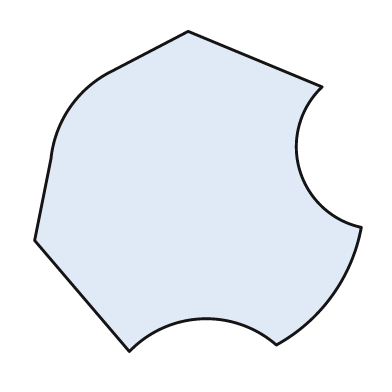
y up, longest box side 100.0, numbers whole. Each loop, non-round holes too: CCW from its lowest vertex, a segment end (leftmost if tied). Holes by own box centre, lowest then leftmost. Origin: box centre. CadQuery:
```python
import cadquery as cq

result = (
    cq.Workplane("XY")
    .moveTo(-21.0, -49.0)
    .threePointArc((1.0, -39.0), (24.0, -47.0))
    .threePointArc((41.0, -32.0), (50.0, -11.0))
    .threePointArc((31.0, 7.0), (38.0, 32.0))
    .lineTo(-3.0, 49.0)
    .lineTo(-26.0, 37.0)
    .threePointArc((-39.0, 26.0), (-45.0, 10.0))
    .lineTo(-50.0, -15.0)
    .close()
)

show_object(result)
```